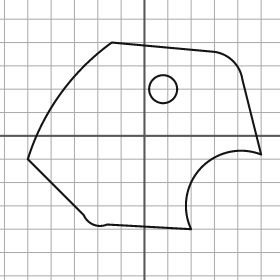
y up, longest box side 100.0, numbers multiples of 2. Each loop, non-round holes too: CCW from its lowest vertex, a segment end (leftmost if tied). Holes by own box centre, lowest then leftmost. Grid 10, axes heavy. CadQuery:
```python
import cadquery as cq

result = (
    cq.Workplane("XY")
    .moveTo(20.0, -40.0)
    .threePointArc((24.0, -14.0), (50.0, -8.0))
    .lineTo(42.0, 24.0)
    .threePointArc((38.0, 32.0), (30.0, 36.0))
    .lineTo(-14.0, 40.0)
    .threePointArc((-36.0, 18.0), (-50.0, -10.0))
    .lineTo(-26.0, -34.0)
    .threePointArc((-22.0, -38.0), (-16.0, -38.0))
    .close()
    .moveTo(8.0, 20.0)
    .circle(6.0)
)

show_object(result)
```